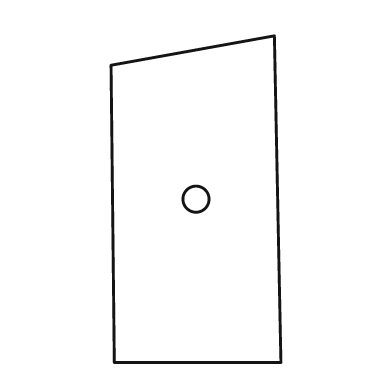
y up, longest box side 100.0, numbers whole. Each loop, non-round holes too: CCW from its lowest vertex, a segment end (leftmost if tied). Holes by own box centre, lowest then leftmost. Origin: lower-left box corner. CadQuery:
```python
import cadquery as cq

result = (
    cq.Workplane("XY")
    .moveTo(1.0, 0.0)
    .lineTo(52.0, 0.0)
    .lineTo(50.0, 100.0)
    .lineTo(0.0, 91.0)
    .close()
    .moveTo(26.0, 50.0)
    .circle(4.0)
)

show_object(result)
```